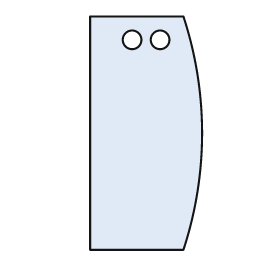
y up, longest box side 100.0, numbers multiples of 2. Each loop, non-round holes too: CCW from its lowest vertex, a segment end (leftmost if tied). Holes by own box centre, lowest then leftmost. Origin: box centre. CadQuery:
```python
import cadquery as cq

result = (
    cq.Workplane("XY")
    .moveTo(-24.0, -50.0)
    .lineTo(16.0, -50.0)
    .threePointArc((24.0, 0.0), (16.0, 50.0))
    .lineTo(-24.0, 50.0)
    .close()
    .moveTo(-6.0, 40.0)
    .circle(4.0)
    .moveTo(6.0, 40.0)
    .circle(4.0)
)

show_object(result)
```